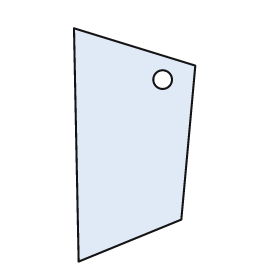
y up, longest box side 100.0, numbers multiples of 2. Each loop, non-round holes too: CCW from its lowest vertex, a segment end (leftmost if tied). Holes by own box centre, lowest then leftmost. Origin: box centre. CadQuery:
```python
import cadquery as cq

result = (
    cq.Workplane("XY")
    .moveTo(-24.0, -50.0)
    .lineTo(20.0, -32.0)
    .lineTo(26.0, 34.0)
    .lineTo(-26.0, 50.0)
    .close()
    .moveTo(12.0, 28.0)
    .circle(4.0)
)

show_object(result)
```